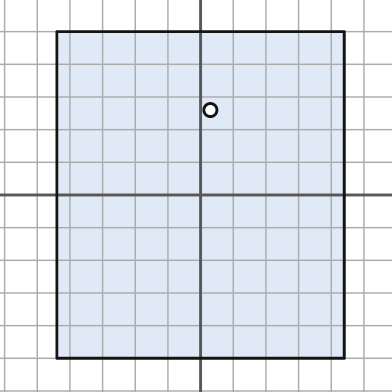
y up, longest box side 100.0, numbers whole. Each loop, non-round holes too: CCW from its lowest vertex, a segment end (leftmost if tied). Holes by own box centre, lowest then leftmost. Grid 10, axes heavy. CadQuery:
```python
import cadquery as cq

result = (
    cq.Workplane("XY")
    .moveTo(-44.0, -50.0)
    .lineTo(44.0, -50.0)
    .lineTo(44.0, 50.0)
    .lineTo(-44.0, 50.0)
    .close()
    .moveTo(3.0, 26.0)
    .circle(2.0)
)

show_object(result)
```